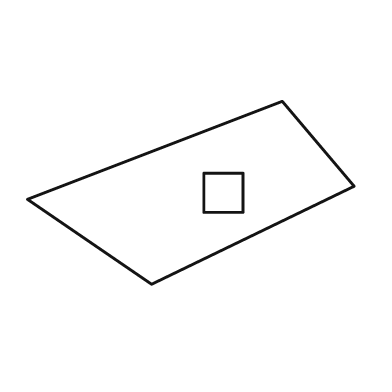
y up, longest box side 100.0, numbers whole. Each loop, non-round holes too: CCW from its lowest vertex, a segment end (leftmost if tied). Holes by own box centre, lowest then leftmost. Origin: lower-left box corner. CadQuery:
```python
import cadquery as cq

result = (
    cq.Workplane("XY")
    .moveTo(38.0, 0.0)
    .lineTo(100.0, 30.0)
    .lineTo(78.0, 56.0)
    .lineTo(0.0, 26.0)
    .close()
    .moveTo(54.0, 22.0)
    .lineTo(66.0, 22.0)
    .lineTo(66.0, 34.0)
    .lineTo(54.0, 34.0)
    .close()
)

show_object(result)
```